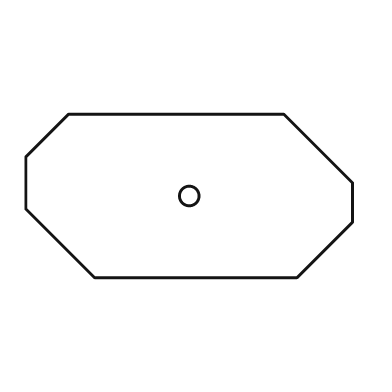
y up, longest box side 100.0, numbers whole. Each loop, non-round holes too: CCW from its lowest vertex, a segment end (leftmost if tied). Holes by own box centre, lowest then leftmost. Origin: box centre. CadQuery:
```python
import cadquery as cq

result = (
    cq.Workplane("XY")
    .moveTo(-29.0, -25.0)
    .lineTo(33.0, -25.0)
    .lineTo(50.0, -8.0)
    .lineTo(50.0, 4.0)
    .lineTo(29.0, 25.0)
    .lineTo(-37.0, 25.0)
    .lineTo(-50.0, 12.0)
    .lineTo(-50.0, -4.0)
    .close()
    .moveTo(0.0, 0.0)
    .circle(3.0)
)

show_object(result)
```